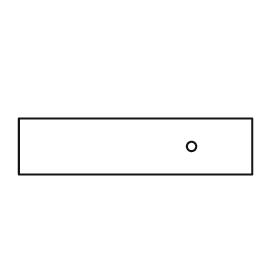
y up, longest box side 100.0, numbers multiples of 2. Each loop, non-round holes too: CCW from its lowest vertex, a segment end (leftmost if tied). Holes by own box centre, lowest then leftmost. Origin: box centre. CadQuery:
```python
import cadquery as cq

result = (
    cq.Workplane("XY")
    .moveTo(-50.0, -12.0)
    .lineTo(50.0, -12.0)
    .lineTo(50.0, 12.0)
    .lineTo(-50.0, 12.0)
    .close()
    .moveTo(24.0, 0.0)
    .circle(2.0)
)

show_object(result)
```